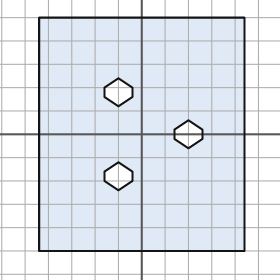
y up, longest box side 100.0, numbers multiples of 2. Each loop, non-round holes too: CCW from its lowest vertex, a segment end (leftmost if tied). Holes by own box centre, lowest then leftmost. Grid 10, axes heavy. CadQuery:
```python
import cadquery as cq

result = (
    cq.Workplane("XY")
    .moveTo(-44.0, -50.0)
    .lineTo(44.0, -50.0)
    .lineTo(44.0, 50.0)
    .lineTo(-44.0, 50.0)
    .close()
    .moveTo(-10.0, -24.0)
    .lineTo(-4.0, -20.0)
    .lineTo(-4.0, -16.0)
    .lineTo(-10.0, -12.0)
    .lineTo(-16.0, -16.0)
    .lineTo(-16.0, -20.0)
    .close()
    .moveTo(20.0, -6.0)
    .lineTo(26.0, -2.0)
    .lineTo(26.0, 2.0)
    .lineTo(20.0, 6.0)
    .lineTo(14.0, 2.0)
    .lineTo(14.0, -2.0)
    .close()
    .moveTo(-10.0, 12.0)
    .lineTo(-4.0, 16.0)
    .lineTo(-4.0, 20.0)
    .lineTo(-10.0, 24.0)
    .lineTo(-16.0, 20.0)
    .lineTo(-16.0, 16.0)
    .close()
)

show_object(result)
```